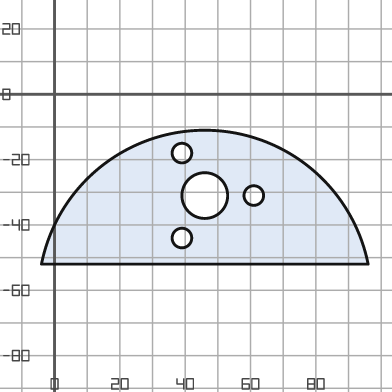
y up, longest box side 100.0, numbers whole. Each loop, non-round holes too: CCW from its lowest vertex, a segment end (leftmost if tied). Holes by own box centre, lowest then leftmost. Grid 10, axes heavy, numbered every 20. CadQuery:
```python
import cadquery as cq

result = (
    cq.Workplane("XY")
    .moveTo(-4.0, -52.0)
    .lineTo(96.0, -52.0)
    .threePointArc((46.0, -11.0), (-4.0, -52.0))
    .close()
    .moveTo(39.0, -44.0)
    .circle(3.0)
    .moveTo(46.0, -31.0)
    .circle(7.0)
    .moveTo(61.0, -31.0)
    .circle(3.0)
    .moveTo(39.0, -18.0)
    .circle(3.0)
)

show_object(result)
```